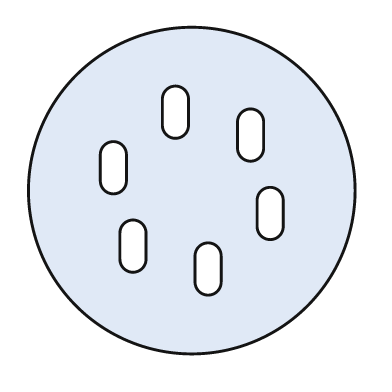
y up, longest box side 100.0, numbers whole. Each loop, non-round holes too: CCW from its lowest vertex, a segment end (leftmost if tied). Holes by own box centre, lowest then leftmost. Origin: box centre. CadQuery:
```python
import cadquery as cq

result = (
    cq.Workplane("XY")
    .moveTo(0.0, 0.0)
    .circle(50.0)
    .moveTo(1.0, -28.0)
    .threePointArc((5.0, -32.0), (9.0, -28.0))
    .lineTo(9.0, -20.0)
    .threePointArc((5.0, -16.0), (1.0, -20.0))
    .close()
    .moveTo(-22.0, -21.0)
    .threePointArc((-18.0, -25.0), (-14.0, -21.0))
    .lineTo(-14.0, -13.0)
    .threePointArc((-18.0, -9.0), (-22.0, -13.0))
    .close()
    .moveTo(20.0, -11.0)
    .threePointArc((24.0, -15.0), (28.0, -11.0))
    .lineTo(28.0, -3.0)
    .threePointArc((24.0, 1.0), (20.0, -3.0))
    .close()
    .moveTo(-28.0, 3.0)
    .threePointArc((-24.0, -1.0), (-20.0, 3.0))
    .lineTo(-20.0, 11.0)
    .threePointArc((-24.0, 15.0), (-28.0, 11.0))
    .close()
    .moveTo(14.0, 13.0)
    .threePointArc((18.0, 9.0), (22.0, 13.0))
    .lineTo(22.0, 21.0)
    .threePointArc((18.0, 25.0), (14.0, 21.0))
    .close()
    .moveTo(-9.0, 20.0)
    .threePointArc((-5.0, 16.0), (-1.0, 20.0))
    .lineTo(-1.0, 28.0)
    .threePointArc((-5.0, 32.0), (-9.0, 28.0))
    .close()
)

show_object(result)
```